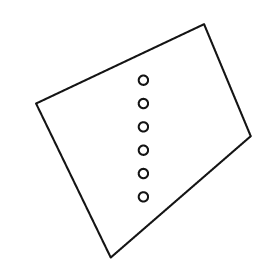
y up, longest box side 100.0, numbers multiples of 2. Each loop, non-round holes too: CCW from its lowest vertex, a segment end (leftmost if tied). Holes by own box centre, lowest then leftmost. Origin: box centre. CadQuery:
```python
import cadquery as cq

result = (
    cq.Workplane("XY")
    .moveTo(-14.0, -50.0)
    .lineTo(46.0, 2.0)
    .lineTo(26.0, 50.0)
    .lineTo(-46.0, 16.0)
    .close()
    .moveTo(0.0, -24.0)
    .circle(2.0)
    .moveTo(0.0, -14.0)
    .circle(2.0)
    .moveTo(0.0, -4.0)
    .circle(2.0)
    .moveTo(0.0, 6.0)
    .circle(2.0)
    .moveTo(0.0, 16.0)
    .circle(2.0)
    .moveTo(0.0, 26.0)
    .circle(2.0)
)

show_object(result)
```